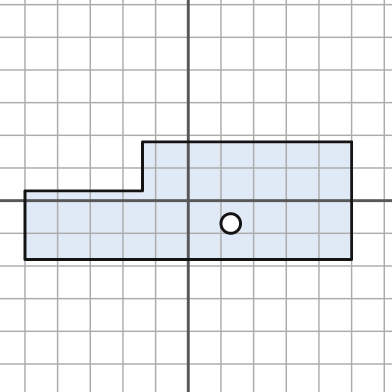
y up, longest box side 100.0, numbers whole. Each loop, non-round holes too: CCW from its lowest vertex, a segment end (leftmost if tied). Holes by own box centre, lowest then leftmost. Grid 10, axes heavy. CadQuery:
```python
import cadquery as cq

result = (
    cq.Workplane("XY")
    .moveTo(-50.0, -18.0)
    .lineTo(50.0, -18.0)
    .lineTo(50.0, 18.0)
    .lineTo(-14.0, 18.0)
    .lineTo(-14.0, 3.0)
    .lineTo(-50.0, 3.0)
    .close()
    .moveTo(13.0, -7.0)
    .circle(3.0)
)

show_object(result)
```